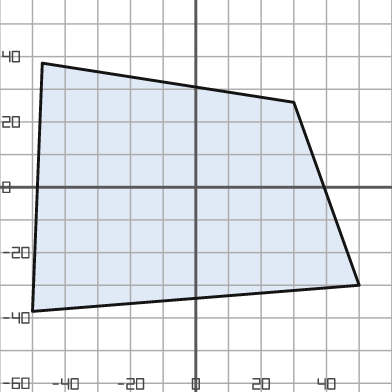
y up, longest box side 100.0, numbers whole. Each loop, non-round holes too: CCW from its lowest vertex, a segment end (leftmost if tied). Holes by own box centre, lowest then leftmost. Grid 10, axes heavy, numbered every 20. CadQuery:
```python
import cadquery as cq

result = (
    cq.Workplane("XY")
    .moveTo(-50.0, -38.0)
    .lineTo(50.0, -30.0)
    .lineTo(30.0, 26.0)
    .lineTo(-47.0, 38.0)
    .close()
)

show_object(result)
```